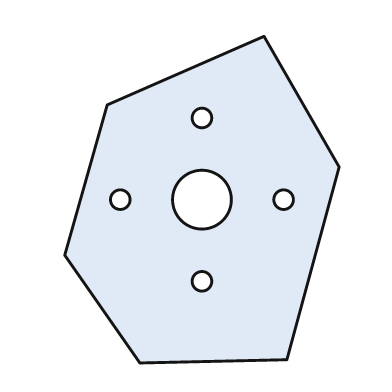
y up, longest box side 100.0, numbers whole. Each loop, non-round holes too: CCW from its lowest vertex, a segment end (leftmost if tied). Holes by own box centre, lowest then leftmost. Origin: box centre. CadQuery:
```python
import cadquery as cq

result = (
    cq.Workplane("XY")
    .moveTo(-19.0, -50.0)
    .lineTo(26.0, -49.0)
    .lineTo(42.0, 10.0)
    .lineTo(19.0, 50.0)
    .lineTo(-29.0, 29.0)
    .lineTo(-42.0, -17.0)
    .close()
    .moveTo(0.0, -25.0)
    .circle(3.0)
    .moveTo(-25.0, 0.0)
    .circle(3.0)
    .moveTo(0.0, 0.0)
    .circle(9.0)
    .moveTo(25.0, 0.0)
    .circle(3.0)
    .moveTo(0.0, 25.0)
    .circle(3.0)
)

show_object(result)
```